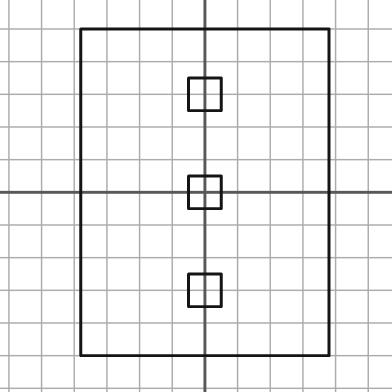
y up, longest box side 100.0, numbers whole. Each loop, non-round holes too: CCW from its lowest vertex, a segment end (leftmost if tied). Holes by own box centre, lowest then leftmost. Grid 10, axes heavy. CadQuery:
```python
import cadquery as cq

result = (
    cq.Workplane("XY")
    .moveTo(-38.0, -50.0)
    .lineTo(38.0, -50.0)
    .lineTo(38.0, 50.0)
    .lineTo(-38.0, 50.0)
    .close()
    .moveTo(-5.0, -35.0)
    .lineTo(5.0, -35.0)
    .lineTo(5.0, -25.0)
    .lineTo(-5.0, -25.0)
    .close()
    .moveTo(-5.0, -5.0)
    .lineTo(5.0, -5.0)
    .lineTo(5.0, 5.0)
    .lineTo(-5.0, 5.0)
    .close()
    .moveTo(-5.0, 25.0)
    .lineTo(5.0, 25.0)
    .lineTo(5.0, 35.0)
    .lineTo(-5.0, 35.0)
    .close()
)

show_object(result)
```